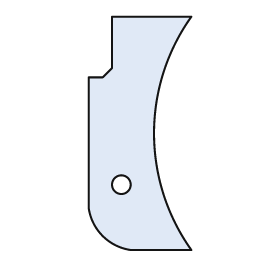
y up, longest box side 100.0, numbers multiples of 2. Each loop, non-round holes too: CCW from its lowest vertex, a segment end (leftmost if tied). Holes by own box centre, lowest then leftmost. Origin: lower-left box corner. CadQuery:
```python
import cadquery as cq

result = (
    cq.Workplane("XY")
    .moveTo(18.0, 0.0)
    .lineTo(44.0, 0.0)
    .threePointArc((28.0, 50.0), (44.0, 100.0))
    .lineTo(10.0, 100.0)
    .lineTo(10.0, 78.0)
    .lineTo(6.0, 74.0)
    .lineTo(0.0, 74.0)
    .lineTo(0.0, 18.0)
    .threePointArc((6.0, 6.0), (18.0, 0.0))
    .close()
    .moveTo(14.0, 28.0)
    .circle(4.0)
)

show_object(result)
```